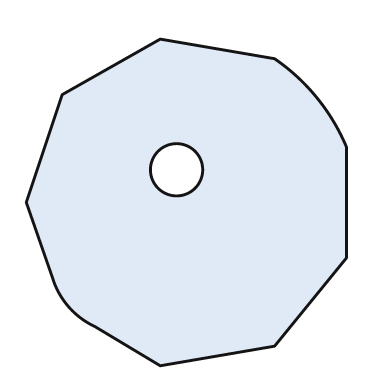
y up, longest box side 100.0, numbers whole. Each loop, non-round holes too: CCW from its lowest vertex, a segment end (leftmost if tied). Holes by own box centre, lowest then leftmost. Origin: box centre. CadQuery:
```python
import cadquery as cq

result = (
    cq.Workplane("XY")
    .moveTo(-8.0, -50.0)
    .lineTo(27.0, -44.0)
    .lineTo(49.0, -17.0)
    .lineTo(49.0, 17.0)
    .threePointArc((40.0, 32.0), (27.0, 44.0))
    .lineTo(-8.0, 50.0)
    .lineTo(-38.0, 33.0)
    .lineTo(-49.0, 0.0)
    .lineTo(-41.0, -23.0)
    .threePointArc((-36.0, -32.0), (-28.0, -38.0))
    .close()
    .moveTo(-3.0, 10.0)
    .circle(8.0)
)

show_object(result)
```